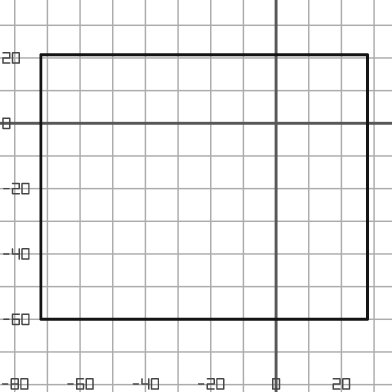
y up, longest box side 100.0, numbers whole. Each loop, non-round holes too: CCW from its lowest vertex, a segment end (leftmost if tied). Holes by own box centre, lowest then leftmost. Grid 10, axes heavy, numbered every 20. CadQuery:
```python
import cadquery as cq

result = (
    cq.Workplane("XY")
    .moveTo(-72.0, -60.0)
    .lineTo(28.0, -60.0)
    .lineTo(28.0, 21.0)
    .lineTo(-72.0, 21.0)
    .close()
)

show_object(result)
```